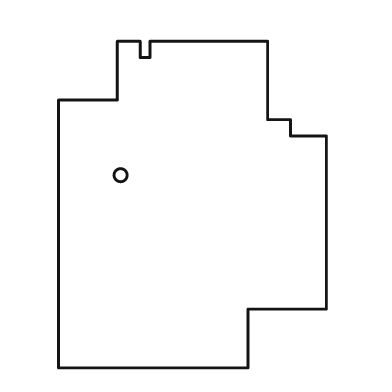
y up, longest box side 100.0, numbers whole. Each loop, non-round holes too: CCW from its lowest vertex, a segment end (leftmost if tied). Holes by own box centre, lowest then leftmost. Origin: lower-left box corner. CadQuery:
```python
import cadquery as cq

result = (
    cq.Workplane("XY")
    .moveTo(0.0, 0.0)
    .lineTo(58.0, 0.0)
    .lineTo(58.0, 18.0)
    .lineTo(82.0, 18.0)
    .lineTo(82.0, 71.0)
    .lineTo(71.0, 71.0)
    .lineTo(71.0, 76.0)
    .lineTo(64.0, 76.0)
    .lineTo(64.0, 100.0)
    .lineTo(28.0, 100.0)
    .lineTo(28.0, 95.0)
    .lineTo(25.0, 95.0)
    .lineTo(25.0, 100.0)
    .lineTo(18.0, 100.0)
    .lineTo(18.0, 82.0)
    .lineTo(0.0, 82.0)
    .close()
    .moveTo(19.0, 59.0)
    .circle(2.0)
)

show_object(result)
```